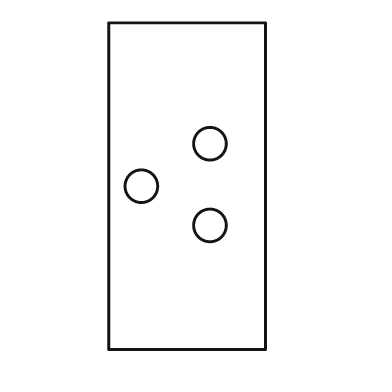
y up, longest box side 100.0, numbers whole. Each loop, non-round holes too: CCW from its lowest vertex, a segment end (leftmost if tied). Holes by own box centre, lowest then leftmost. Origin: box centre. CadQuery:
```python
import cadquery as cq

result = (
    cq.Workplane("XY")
    .moveTo(-24.0, -50.0)
    .lineTo(24.0, -50.0)
    .lineTo(24.0, 50.0)
    .lineTo(-24.0, 50.0)
    .close()
    .moveTo(7.0, -12.0)
    .circle(5.0)
    .moveTo(-14.0, 0.0)
    .circle(5.0)
    .moveTo(7.0, 13.0)
    .circle(5.0)
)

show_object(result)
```